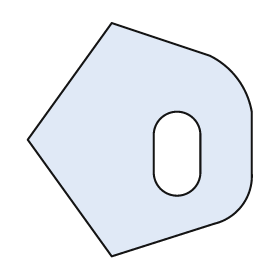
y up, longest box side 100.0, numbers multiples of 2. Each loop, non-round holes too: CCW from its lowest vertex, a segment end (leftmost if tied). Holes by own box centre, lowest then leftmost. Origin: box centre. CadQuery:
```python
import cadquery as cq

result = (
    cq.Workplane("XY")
    .moveTo(-12.0, -50.0)
    .lineTo(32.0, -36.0)
    .threePointArc((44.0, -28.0), (48.0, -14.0))
    .lineTo(48.0, 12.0)
    .threePointArc((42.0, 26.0), (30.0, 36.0))
    .lineTo(-12.0, 50.0)
    .lineTo(-48.0, 0.0)
    .close()
    .moveTo(6.0, -14.0)
    .threePointArc((16.0, -24.0), (26.0, -14.0))
    .lineTo(26.0, 2.0)
    .threePointArc((16.0, 12.0), (6.0, 2.0))
    .close()
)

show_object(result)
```